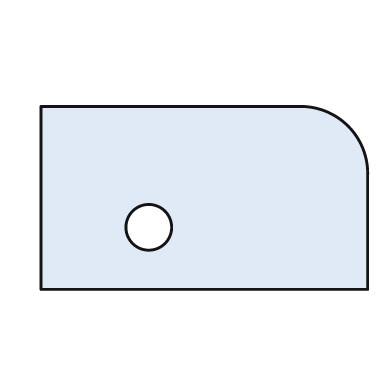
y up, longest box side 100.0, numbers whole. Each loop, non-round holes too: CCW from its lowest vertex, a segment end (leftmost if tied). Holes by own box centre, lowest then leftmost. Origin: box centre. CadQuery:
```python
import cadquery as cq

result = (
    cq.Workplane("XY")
    .moveTo(-50.0, -28.0)
    .lineTo(50.0, -28.0)
    .lineTo(50.0, 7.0)
    .threePointArc((44.0, 22.0), (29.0, 28.0))
    .lineTo(-50.0, 28.0)
    .close()
    .moveTo(-17.0, -9.0)
    .circle(7.0)
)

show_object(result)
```